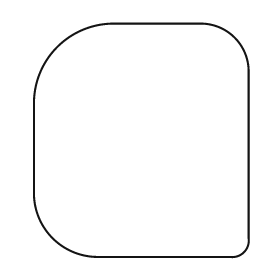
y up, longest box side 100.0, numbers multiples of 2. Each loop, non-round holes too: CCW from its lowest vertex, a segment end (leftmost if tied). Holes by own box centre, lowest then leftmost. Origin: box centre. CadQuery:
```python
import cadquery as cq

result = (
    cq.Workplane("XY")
    .moveTo(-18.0, -50.0)
    .lineTo(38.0, -50.0)
    .threePointArc((44.0, -48.0), (46.0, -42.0))
    .lineTo(46.0, 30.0)
    .threePointArc((40.0, 44.0), (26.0, 50.0))
    .lineTo(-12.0, 50.0)
    .threePointArc((-36.0, 40.0), (-46.0, 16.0))
    .lineTo(-46.0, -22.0)
    .threePointArc((-38.0, -42.0), (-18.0, -50.0))
    .close()
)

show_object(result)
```